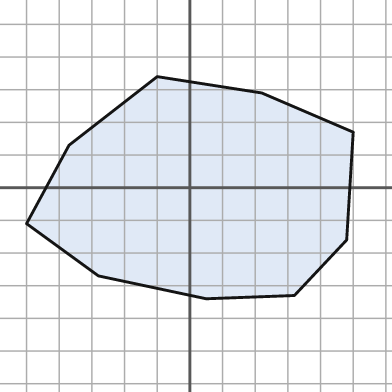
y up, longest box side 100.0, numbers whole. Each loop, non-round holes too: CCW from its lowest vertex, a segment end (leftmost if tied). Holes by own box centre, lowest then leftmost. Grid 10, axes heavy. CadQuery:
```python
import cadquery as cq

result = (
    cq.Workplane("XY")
    .moveTo(5.0, -34.0)
    .lineTo(32.0, -33.0)
    .lineTo(48.0, -16.0)
    .lineTo(50.0, 17.0)
    .lineTo(22.0, 29.0)
    .lineTo(-10.0, 34.0)
    .lineTo(-37.0, 13.0)
    .lineTo(-50.0, -11.0)
    .lineTo(-28.0, -27.0)
    .close()
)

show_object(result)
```